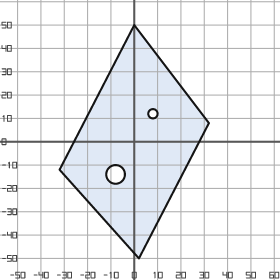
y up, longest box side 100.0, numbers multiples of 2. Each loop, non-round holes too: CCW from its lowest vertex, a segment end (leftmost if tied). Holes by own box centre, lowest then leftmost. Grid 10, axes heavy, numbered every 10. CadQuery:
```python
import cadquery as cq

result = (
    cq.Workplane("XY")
    .moveTo(2.0, -50.0)
    .lineTo(32.0, 8.0)
    .lineTo(0.0, 50.0)
    .lineTo(-32.0, -12.0)
    .close()
    .moveTo(-8.0, -14.0)
    .circle(4.0)
    .moveTo(8.0, 12.0)
    .circle(2.0)
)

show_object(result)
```